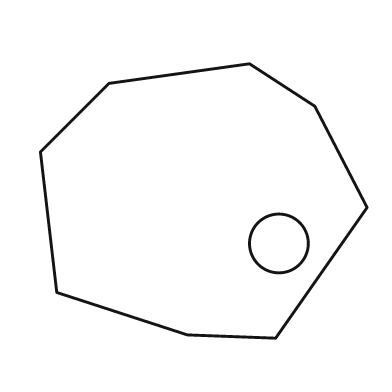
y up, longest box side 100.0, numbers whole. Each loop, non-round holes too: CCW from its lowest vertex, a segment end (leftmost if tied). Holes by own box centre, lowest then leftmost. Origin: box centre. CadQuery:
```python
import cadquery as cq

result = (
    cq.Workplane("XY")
    .moveTo(22.0, -42.0)
    .lineTo(50.0, -2.0)
    .lineTo(34.0, 29.0)
    .lineTo(14.0, 42.0)
    .lineTo(-29.0, 36.0)
    .lineTo(-50.0, 15.0)
    .lineTo(-45.0, -28.0)
    .lineTo(-5.0, -41.0)
    .close()
    .moveTo(23.0, -13.0)
    .circle(9.0)
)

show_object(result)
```